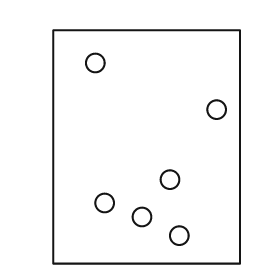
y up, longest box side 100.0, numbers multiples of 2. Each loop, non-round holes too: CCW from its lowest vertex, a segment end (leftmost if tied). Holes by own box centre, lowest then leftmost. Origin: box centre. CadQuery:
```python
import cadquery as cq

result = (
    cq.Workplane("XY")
    .moveTo(-40.0, -50.0)
    .lineTo(40.0, -50.0)
    .lineTo(40.0, 50.0)
    .lineTo(-40.0, 50.0)
    .close()
    .moveTo(14.0, -38.0)
    .circle(4.0)
    .moveTo(-2.0, -30.0)
    .circle(4.0)
    .moveTo(-18.0, -24.0)
    .circle(4.0)
    .moveTo(10.0, -14.0)
    .circle(4.0)
    .moveTo(30.0, 16.0)
    .circle(4.0)
    .moveTo(-22.0, 36.0)
    .circle(4.0)
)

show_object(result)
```